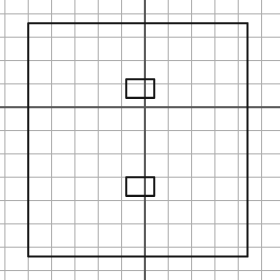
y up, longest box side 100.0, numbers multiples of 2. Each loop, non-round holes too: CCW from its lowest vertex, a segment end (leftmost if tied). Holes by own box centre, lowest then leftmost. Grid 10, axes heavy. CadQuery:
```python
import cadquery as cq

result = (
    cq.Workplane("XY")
    .moveTo(-50.0, -64.0)
    .lineTo(44.0, -64.0)
    .lineTo(44.0, 36.0)
    .lineTo(-50.0, 36.0)
    .close()
    .moveTo(-8.0, -38.0)
    .lineTo(4.0, -38.0)
    .lineTo(4.0, -30.0)
    .lineTo(-8.0, -30.0)
    .close()
    .moveTo(-8.0, 4.0)
    .lineTo(4.0, 4.0)
    .lineTo(4.0, 12.0)
    .lineTo(-8.0, 12.0)
    .close()
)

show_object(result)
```